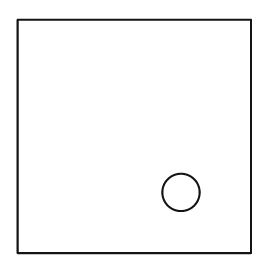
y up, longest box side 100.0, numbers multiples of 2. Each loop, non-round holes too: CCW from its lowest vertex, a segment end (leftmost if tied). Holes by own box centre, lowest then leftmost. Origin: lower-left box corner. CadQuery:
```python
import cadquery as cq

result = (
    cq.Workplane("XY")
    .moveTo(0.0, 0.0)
    .lineTo(100.0, 0.0)
    .lineTo(100.0, 100.0)
    .lineTo(0.0, 100.0)
    .close()
    .moveTo(70.0, 26.0)
    .circle(8.0)
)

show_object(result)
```